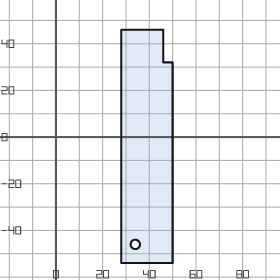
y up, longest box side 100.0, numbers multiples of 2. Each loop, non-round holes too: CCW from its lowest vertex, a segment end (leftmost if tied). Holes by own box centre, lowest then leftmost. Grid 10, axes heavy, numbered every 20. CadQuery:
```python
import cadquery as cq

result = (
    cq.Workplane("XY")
    .moveTo(28.0, -54.0)
    .lineTo(50.0, -54.0)
    .lineTo(50.0, 32.0)
    .lineTo(46.0, 32.0)
    .lineTo(46.0, 46.0)
    .lineTo(28.0, 46.0)
    .close()
    .moveTo(34.0, -46.0)
    .circle(2.0)
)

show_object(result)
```